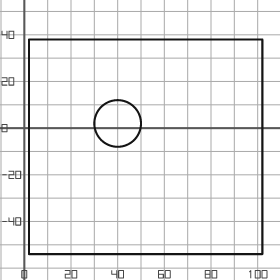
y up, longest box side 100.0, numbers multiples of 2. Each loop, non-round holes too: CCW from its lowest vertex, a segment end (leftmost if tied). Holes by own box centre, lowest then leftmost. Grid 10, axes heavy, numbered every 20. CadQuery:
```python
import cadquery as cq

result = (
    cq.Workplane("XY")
    .moveTo(2.0, -54.0)
    .lineTo(102.0, -54.0)
    .lineTo(102.0, 38.0)
    .lineTo(2.0, 38.0)
    .close()
    .moveTo(40.0, 2.0)
    .circle(10.0)
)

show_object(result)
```